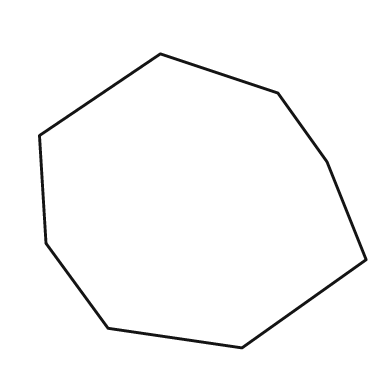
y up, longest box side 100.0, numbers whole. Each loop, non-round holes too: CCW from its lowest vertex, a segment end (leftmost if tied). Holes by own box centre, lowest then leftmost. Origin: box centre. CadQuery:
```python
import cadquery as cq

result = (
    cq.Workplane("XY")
    .moveTo(12.0, -45.0)
    .lineTo(50.0, -18.0)
    .lineTo(38.0, 12.0)
    .lineTo(23.0, 33.0)
    .lineTo(-13.0, 45.0)
    .lineTo(-50.0, 20.0)
    .lineTo(-48.0, -13.0)
    .lineTo(-29.0, -39.0)
    .close()
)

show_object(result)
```